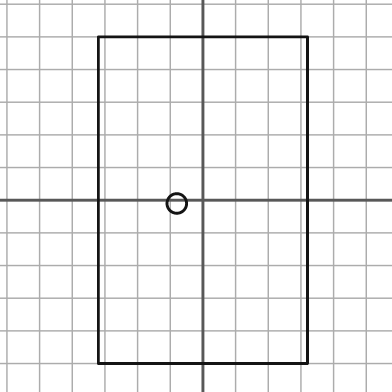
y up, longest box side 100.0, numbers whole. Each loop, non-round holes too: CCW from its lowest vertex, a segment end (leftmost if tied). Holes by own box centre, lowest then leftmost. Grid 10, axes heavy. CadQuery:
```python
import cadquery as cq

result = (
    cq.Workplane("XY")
    .moveTo(-32.0, -50.0)
    .lineTo(32.0, -50.0)
    .lineTo(32.0, 50.0)
    .lineTo(-32.0, 50.0)
    .close()
    .moveTo(-8.0, -1.0)
    .circle(3.0)
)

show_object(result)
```